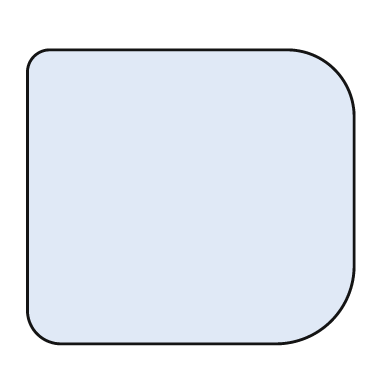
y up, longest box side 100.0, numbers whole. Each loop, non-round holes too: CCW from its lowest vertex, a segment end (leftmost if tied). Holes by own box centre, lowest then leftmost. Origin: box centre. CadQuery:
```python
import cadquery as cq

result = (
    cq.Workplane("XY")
    .moveTo(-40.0, -45.0)
    .lineTo(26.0, -45.0)
    .threePointArc((43.0, -38.0), (50.0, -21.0))
    .lineTo(50.0, 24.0)
    .threePointArc((44.0, 39.0), (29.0, 45.0))
    .lineTo(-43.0, 45.0)
    .threePointArc((-48.0, 43.0), (-50.0, 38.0))
    .lineTo(-50.0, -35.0)
    .threePointArc((-47.0, -42.0), (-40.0, -45.0))
    .close()
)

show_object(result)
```